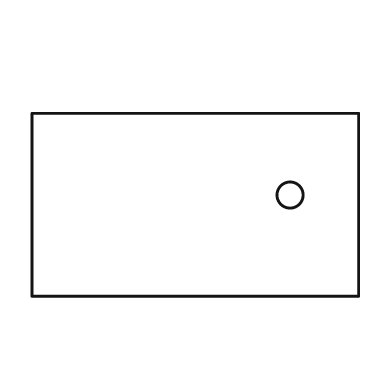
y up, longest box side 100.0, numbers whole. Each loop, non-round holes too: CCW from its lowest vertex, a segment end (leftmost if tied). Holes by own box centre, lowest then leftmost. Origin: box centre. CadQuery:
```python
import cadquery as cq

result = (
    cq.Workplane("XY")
    .moveTo(-50.0, -28.0)
    .lineTo(50.0, -28.0)
    .lineTo(50.0, 28.0)
    .lineTo(-50.0, 28.0)
    .close()
    .moveTo(29.0, 3.0)
    .circle(4.0)
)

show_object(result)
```